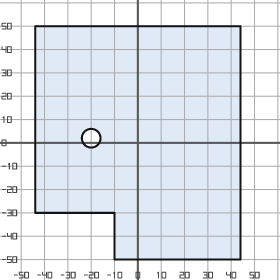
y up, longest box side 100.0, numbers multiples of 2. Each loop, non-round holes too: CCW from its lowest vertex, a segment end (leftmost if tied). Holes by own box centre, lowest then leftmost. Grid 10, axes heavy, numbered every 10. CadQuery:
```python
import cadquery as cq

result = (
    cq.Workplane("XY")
    .moveTo(-10.0, -50.0)
    .lineTo(44.0, -50.0)
    .lineTo(44.0, 50.0)
    .lineTo(-44.0, 50.0)
    .lineTo(-44.0, -30.0)
    .lineTo(-10.0, -30.0)
    .close()
    .moveTo(-20.0, 2.0)
    .circle(4.0)
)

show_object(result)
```